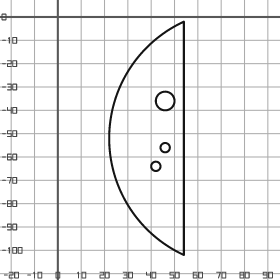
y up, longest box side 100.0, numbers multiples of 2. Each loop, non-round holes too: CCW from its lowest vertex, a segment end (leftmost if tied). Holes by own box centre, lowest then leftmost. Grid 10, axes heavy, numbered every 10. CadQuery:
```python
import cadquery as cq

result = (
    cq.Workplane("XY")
    .moveTo(54.0, -102.0)
    .lineTo(54.0, -2.0)
    .threePointArc((22.0, -52.0), (54.0, -102.0))
    .close()
    .moveTo(42.0, -64.0)
    .circle(2.0)
    .moveTo(46.0, -56.0)
    .circle(2.0)
    .moveTo(46.0, -36.0)
    .circle(4.0)
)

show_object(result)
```